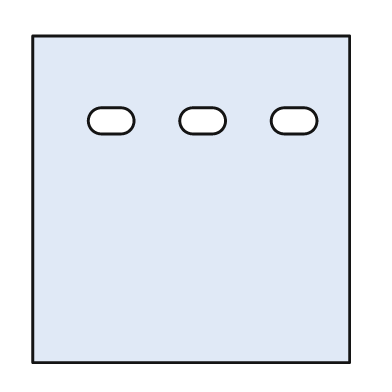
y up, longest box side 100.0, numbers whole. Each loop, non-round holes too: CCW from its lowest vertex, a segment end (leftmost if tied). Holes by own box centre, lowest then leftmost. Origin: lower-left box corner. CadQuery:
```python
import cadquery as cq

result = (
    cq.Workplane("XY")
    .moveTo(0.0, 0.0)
    .lineTo(97.0, 0.0)
    .lineTo(97.0, 100.0)
    .lineTo(0.0, 100.0)
    .close()
    .moveTo(21.0, 70.0)
    .lineTo(27.0, 70.0)
    .threePointArc((31.0, 74.0), (27.0, 78.0))
    .lineTo(21.0, 78.0)
    .threePointArc((17.0, 74.0), (21.0, 70.0))
    .close()
    .moveTo(49.0, 70.0)
    .lineTo(55.0, 70.0)
    .threePointArc((59.0, 74.0), (55.0, 78.0))
    .lineTo(49.0, 78.0)
    .threePointArc((45.0, 74.0), (49.0, 70.0))
    .close()
    .moveTo(77.0, 70.0)
    .lineTo(83.0, 70.0)
    .threePointArc((87.0, 74.0), (83.0, 78.0))
    .lineTo(77.0, 78.0)
    .threePointArc((73.0, 74.0), (77.0, 70.0))
    .close()
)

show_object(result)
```